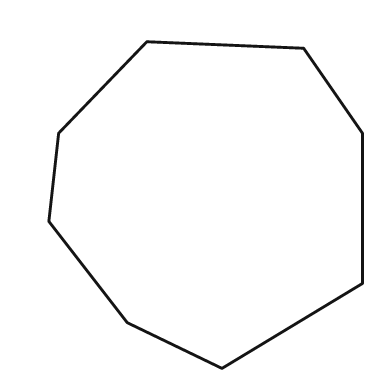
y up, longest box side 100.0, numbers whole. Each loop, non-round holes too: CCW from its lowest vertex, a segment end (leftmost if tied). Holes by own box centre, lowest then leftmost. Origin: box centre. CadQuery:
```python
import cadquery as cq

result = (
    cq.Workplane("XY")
    .moveTo(5.0, -50.0)
    .lineTo(48.0, -24.0)
    .lineTo(48.0, 22.0)
    .lineTo(30.0, 48.0)
    .lineTo(-18.0, 50.0)
    .lineTo(-45.0, 22.0)
    .lineTo(-48.0, -5.0)
    .lineTo(-24.0, -36.0)
    .close()
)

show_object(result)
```